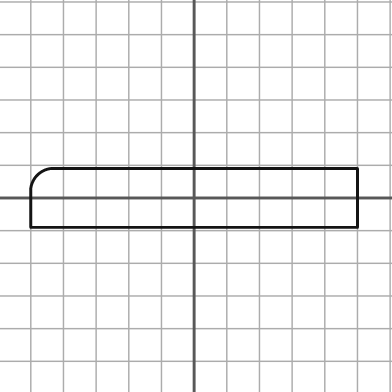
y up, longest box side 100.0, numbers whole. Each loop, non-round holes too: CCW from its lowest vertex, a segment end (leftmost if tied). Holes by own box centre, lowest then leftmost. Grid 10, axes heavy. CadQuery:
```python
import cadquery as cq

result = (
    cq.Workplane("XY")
    .moveTo(-50.0, -9.0)
    .lineTo(50.0, -9.0)
    .lineTo(50.0, 9.0)
    .lineTo(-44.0, 9.0)
    .threePointArc((-48.0, 7.0), (-50.0, 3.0))
    .close()
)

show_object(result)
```